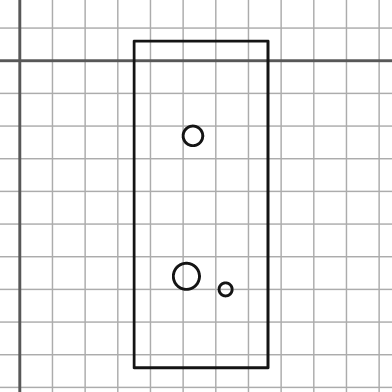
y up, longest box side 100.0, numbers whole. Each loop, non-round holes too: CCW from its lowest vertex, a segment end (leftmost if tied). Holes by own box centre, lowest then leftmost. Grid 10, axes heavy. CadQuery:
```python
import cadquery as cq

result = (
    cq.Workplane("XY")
    .moveTo(35.0, -94.0)
    .lineTo(76.0, -94.0)
    .lineTo(76.0, 6.0)
    .lineTo(35.0, 6.0)
    .close()
    .moveTo(63.0, -70.0)
    .circle(2.0)
    .moveTo(51.0, -66.0)
    .circle(4.0)
    .moveTo(53.0, -23.0)
    .circle(3.0)
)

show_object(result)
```